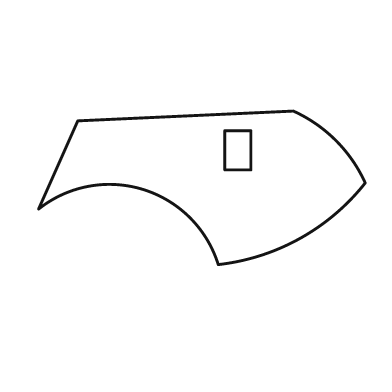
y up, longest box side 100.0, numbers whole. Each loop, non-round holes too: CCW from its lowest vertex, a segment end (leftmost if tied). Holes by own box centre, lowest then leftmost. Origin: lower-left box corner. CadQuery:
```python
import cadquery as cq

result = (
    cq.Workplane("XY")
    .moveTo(55.0, 0.0)
    .threePointArc((80.0, 8.0), (100.0, 25.0))
    .threePointArc((91.0, 38.0), (78.0, 47.0))
    .lineTo(12.0, 44.0)
    .lineTo(0.0, 17.0)
    .threePointArc((32.0, 23.0), (55.0, 0.0))
    .close()
    .moveTo(57.0, 29.0)
    .lineTo(65.0, 29.0)
    .lineTo(65.0, 41.0)
    .lineTo(57.0, 41.0)
    .close()
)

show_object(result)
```